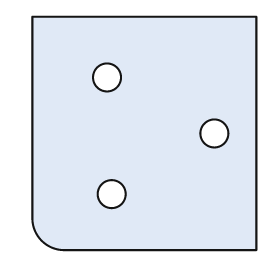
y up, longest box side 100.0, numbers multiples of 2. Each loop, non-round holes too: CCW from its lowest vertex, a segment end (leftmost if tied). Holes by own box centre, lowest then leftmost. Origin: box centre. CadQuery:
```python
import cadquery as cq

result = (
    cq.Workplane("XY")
    .moveTo(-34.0, -50.0)
    .lineTo(48.0, -50.0)
    .lineTo(48.0, 50.0)
    .lineTo(-48.0, 50.0)
    .lineTo(-48.0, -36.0)
    .threePointArc((-44.0, -46.0), (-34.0, -50.0))
    .close()
    .moveTo(-14.0, -26.0)
    .circle(6.0)
    .moveTo(30.0, 0.0)
    .circle(6.0)
    .moveTo(-16.0, 24.0)
    .circle(6.0)
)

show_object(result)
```